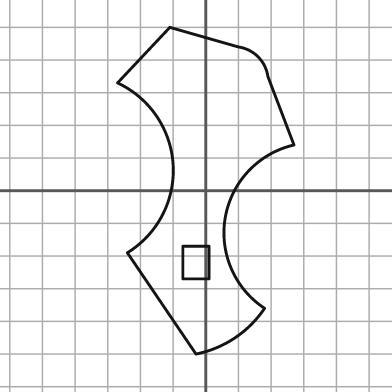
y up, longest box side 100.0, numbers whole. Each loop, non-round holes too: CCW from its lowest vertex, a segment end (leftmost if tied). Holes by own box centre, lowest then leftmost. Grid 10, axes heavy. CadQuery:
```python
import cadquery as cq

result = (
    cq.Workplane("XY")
    .moveTo(-3.0, -50.0)
    .threePointArc((9.0, -45.0), (18.0, -36.0))
    .threePointArc((6.0, -8.0), (27.0, 14.0))
    .lineTo(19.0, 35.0)
    .threePointArc((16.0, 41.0), (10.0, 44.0))
    .lineTo(-11.0, 50.0)
    .lineTo(-27.0, 33.0)
    .threePointArc((-10.0, 8.0), (-24.0, -19.0))
    .close()
    .moveTo(-7.0, -27.0)
    .lineTo(1.0, -27.0)
    .lineTo(1.0, -17.0)
    .lineTo(-7.0, -17.0)
    .close()
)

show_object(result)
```